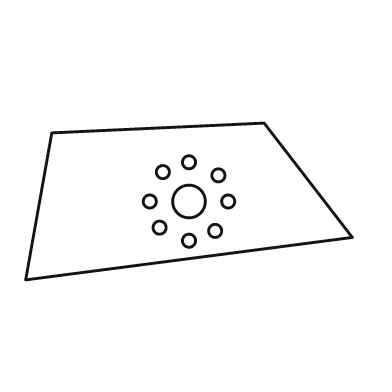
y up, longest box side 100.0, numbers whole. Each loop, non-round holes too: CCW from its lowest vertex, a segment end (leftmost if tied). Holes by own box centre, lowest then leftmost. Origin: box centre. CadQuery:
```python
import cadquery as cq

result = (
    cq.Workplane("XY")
    .moveTo(-50.0, -24.0)
    .lineTo(50.0, -11.0)
    .lineTo(23.0, 24.0)
    .lineTo(-42.0, 21.0)
    .close()
    .moveTo(0.0, -12.0)
    .circle(2.0)
    .moveTo(8.0, -9.0)
    .circle(2.0)
    .moveTo(-9.0, -8.0)
    .circle(2.0)
    .moveTo(-12.0, 0.0)
    .circle(2.0)
    .moveTo(0.0, 0.0)
    .circle(5.0)
    .moveTo(12.0, 0.0)
    .circle(2.0)
    .moveTo(9.0, 8.0)
    .circle(2.0)
    .moveTo(-8.0, 9.0)
    .circle(2.0)
    .moveTo(0.0, 12.0)
    .circle(2.0)
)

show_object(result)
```